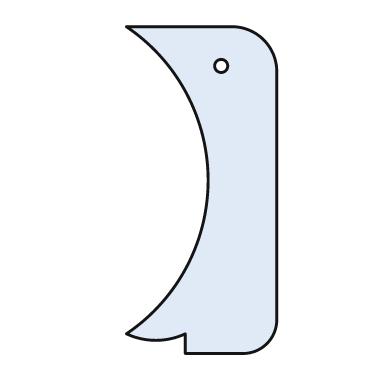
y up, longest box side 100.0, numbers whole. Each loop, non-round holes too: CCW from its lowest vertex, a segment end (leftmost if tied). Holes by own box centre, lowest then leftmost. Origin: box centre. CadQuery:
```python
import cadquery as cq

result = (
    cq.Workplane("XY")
    .moveTo(-5.0, -50.0)
    .lineTo(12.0, -50.0)
    .threePointArc((20.0, -47.0), (23.0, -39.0))
    .lineTo(23.0, 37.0)
    .threePointArc((19.0, 46.0), (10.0, 50.0))
    .lineTo(-23.0, 50.0)
    .threePointArc((2.0, 3.0), (-23.0, -44.0))
    .threePointArc((-14.0, -46.0), (-5.0, -44.0))
    .close()
    .moveTo(6.0, 38.0)
    .circle(2.0)
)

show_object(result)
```